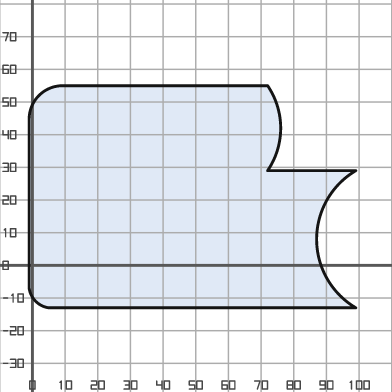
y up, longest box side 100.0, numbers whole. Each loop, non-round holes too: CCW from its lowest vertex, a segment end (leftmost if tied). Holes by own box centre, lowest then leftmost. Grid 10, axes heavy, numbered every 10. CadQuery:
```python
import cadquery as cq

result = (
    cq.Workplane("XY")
    .moveTo(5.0, -13.0)
    .lineTo(99.0, -13.0)
    .threePointArc((87.0, 8.0), (99.0, 29.0))
    .lineTo(72.0, 29.0)
    .threePointArc((76.0, 42.0), (72.0, 55.0))
    .lineTo(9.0, 55.0)
    .threePointArc((2.0, 52.0), (-1.0, 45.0))
    .lineTo(-1.0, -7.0)
    .threePointArc((1.0, -11.0), (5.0, -13.0))
    .close()
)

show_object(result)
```